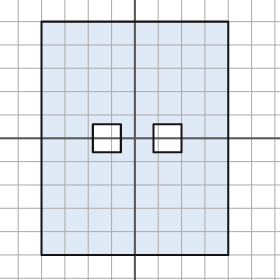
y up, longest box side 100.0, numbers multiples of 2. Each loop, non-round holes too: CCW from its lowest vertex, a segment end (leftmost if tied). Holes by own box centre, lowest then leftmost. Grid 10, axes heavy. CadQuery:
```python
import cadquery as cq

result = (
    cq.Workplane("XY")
    .moveTo(-40.0, -50.0)
    .lineTo(40.0, -50.0)
    .lineTo(40.0, 50.0)
    .lineTo(-40.0, 50.0)
    .close()
    .moveTo(-18.0, -6.0)
    .lineTo(-6.0, -6.0)
    .lineTo(-6.0, 6.0)
    .lineTo(-18.0, 6.0)
    .close()
    .moveTo(8.0, -6.0)
    .lineTo(20.0, -6.0)
    .lineTo(20.0, 6.0)
    .lineTo(8.0, 6.0)
    .close()
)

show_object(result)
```